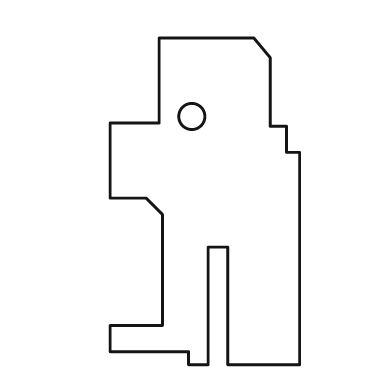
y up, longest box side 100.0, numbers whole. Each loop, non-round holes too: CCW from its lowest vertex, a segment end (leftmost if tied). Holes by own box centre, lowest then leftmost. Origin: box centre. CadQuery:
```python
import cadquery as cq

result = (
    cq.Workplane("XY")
    .moveTo(-5.0, -50.0)
    .lineTo(1.0, -50.0)
    .lineTo(1.0, -14.0)
    .lineTo(7.0, -14.0)
    .lineTo(7.0, -50.0)
    .lineTo(29.0, -50.0)
    .lineTo(29.0, 15.0)
    .lineTo(25.0, 15.0)
    .lineTo(25.0, 23.0)
    .lineTo(20.0, 23.0)
    .lineTo(20.0, 44.0)
    .lineTo(15.0, 50.0)
    .lineTo(-14.0, 50.0)
    .lineTo(-14.0, 24.0)
    .lineTo(-29.0, 24.0)
    .lineTo(-29.0, 1.0)
    .lineTo(-18.0, 1.0)
    .lineTo(-13.0, -4.0)
    .lineTo(-13.0, -38.0)
    .lineTo(-29.0, -38.0)
    .lineTo(-29.0, -46.0)
    .lineTo(-5.0, -46.0)
    .close()
    .moveTo(-4.0, 26.0)
    .circle(4.0)
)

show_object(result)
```